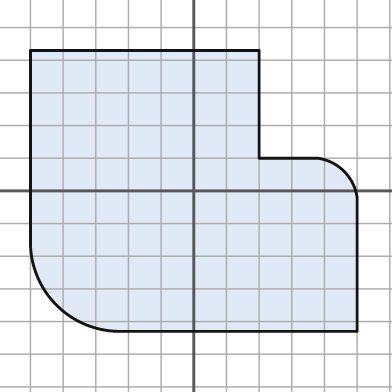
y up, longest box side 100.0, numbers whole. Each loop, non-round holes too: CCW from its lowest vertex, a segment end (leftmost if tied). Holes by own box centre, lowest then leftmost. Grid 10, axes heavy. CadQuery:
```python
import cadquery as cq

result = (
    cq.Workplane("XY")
    .moveTo(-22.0, -43.0)
    .lineTo(50.0, -43.0)
    .lineTo(50.0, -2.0)
    .threePointArc((46.0, 6.0), (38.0, 10.0))
    .lineTo(20.0, 10.0)
    .lineTo(20.0, 43.0)
    .lineTo(-50.0, 43.0)
    .lineTo(-50.0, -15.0)
    .threePointArc((-42.0, -35.0), (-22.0, -43.0))
    .close()
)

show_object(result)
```